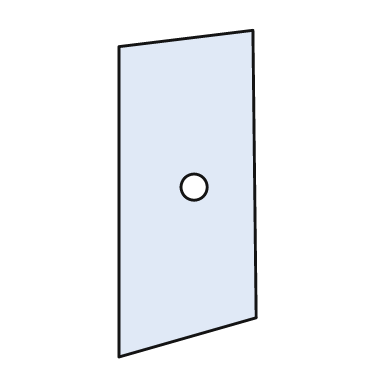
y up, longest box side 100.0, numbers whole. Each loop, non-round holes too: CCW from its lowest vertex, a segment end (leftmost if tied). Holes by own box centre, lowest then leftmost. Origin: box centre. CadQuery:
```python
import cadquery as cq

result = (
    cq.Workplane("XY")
    .moveTo(-21.0, -50.0)
    .lineTo(21.0, -38.0)
    .lineTo(20.0, 50.0)
    .lineTo(-21.0, 45.0)
    .close()
    .moveTo(2.0, 2.0)
    .circle(4.0)
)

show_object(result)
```